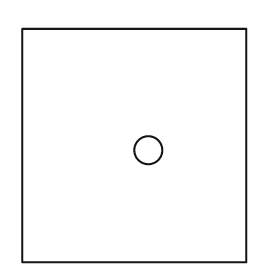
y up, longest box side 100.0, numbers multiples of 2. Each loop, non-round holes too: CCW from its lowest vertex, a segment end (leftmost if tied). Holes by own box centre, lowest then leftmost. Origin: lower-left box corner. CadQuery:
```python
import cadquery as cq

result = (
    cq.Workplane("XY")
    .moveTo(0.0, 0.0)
    .lineTo(96.0, 0.0)
    .lineTo(96.0, 100.0)
    .lineTo(0.0, 100.0)
    .close()
    .moveTo(54.0, 48.0)
    .circle(6.0)
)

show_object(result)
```